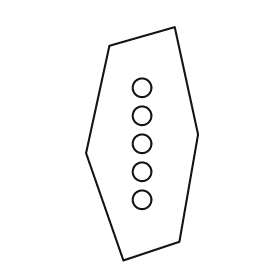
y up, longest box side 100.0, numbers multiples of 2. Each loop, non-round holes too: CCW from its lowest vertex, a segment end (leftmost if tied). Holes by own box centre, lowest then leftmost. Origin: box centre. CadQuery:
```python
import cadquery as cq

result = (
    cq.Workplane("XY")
    .moveTo(-8.0, -50.0)
    .lineTo(16.0, -42.0)
    .lineTo(24.0, 4.0)
    .lineTo(14.0, 50.0)
    .lineTo(-14.0, 42.0)
    .lineTo(-24.0, -4.0)
    .close()
    .moveTo(0.0, -24.0)
    .circle(4.0)
    .moveTo(0.0, -12.0)
    .circle(4.0)
    .moveTo(0.0, 0.0)
    .circle(4.0)
    .moveTo(0.0, 12.0)
    .circle(4.0)
    .moveTo(0.0, 24.0)
    .circle(4.0)
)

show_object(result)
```